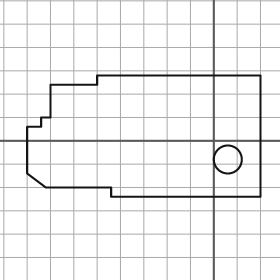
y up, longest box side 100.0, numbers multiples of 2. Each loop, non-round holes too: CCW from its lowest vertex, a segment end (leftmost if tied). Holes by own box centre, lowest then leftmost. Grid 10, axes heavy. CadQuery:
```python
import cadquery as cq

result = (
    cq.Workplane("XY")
    .moveTo(-44.0, -24.0)
    .lineTo(20.0, -24.0)
    .lineTo(20.0, 28.0)
    .lineTo(-50.0, 28.0)
    .lineTo(-50.0, 24.0)
    .lineTo(-70.0, 24.0)
    .lineTo(-70.0, 10.0)
    .lineTo(-74.0, 10.0)
    .lineTo(-74.0, 6.0)
    .lineTo(-80.0, 6.0)
    .lineTo(-80.0, -14.0)
    .lineTo(-72.0, -20.0)
    .lineTo(-44.0, -20.0)
    .close()
    .moveTo(6.0, -8.0)
    .circle(6.0)
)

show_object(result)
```